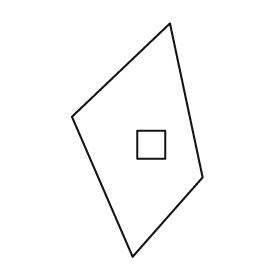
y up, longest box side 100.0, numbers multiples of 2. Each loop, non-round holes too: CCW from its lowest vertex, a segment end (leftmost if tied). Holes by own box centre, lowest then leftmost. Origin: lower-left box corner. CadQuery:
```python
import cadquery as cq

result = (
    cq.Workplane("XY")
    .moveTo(26.0, 0.0)
    .lineTo(56.0, 34.0)
    .lineTo(42.0, 100.0)
    .lineTo(0.0, 60.0)
    .close()
    .moveTo(28.0, 42.0)
    .lineTo(40.0, 42.0)
    .lineTo(40.0, 54.0)
    .lineTo(28.0, 54.0)
    .close()
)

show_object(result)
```